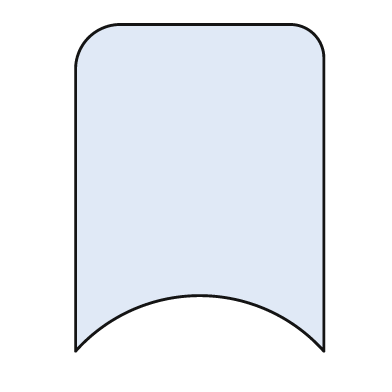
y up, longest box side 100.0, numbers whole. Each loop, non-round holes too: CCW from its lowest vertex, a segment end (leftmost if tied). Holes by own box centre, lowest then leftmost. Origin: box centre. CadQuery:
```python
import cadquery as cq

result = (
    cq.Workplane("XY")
    .moveTo(-38.0, -50.0)
    .threePointArc((0.0, -33.0), (38.0, -50.0))
    .lineTo(38.0, 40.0)
    .threePointArc((35.0, 47.0), (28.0, 50.0))
    .lineTo(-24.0, 50.0)
    .threePointArc((-34.0, 46.0), (-38.0, 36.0))
    .close()
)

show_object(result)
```